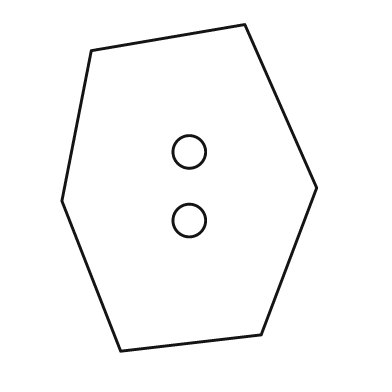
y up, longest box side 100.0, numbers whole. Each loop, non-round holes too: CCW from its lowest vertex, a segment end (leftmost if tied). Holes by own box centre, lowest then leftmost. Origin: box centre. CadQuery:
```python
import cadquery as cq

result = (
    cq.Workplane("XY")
    .moveTo(-21.0, -50.0)
    .lineTo(22.0, -45.0)
    .lineTo(39.0, 0.0)
    .lineTo(17.0, 50.0)
    .lineTo(-30.0, 42.0)
    .lineTo(-39.0, -4.0)
    .close()
    .moveTo(0.0, -10.0)
    .circle(5.0)
    .moveTo(0.0, 11.0)
    .circle(5.0)
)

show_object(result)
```